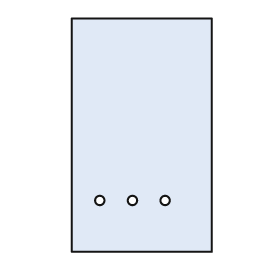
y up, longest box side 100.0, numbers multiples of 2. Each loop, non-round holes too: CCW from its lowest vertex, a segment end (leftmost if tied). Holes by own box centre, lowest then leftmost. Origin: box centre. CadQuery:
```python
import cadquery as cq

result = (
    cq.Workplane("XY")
    .moveTo(-30.0, -50.0)
    .lineTo(30.0, -50.0)
    .lineTo(30.0, 50.0)
    .lineTo(-30.0, 50.0)
    .close()
    .moveTo(-18.0, -28.0)
    .circle(2.0)
    .moveTo(-4.0, -28.0)
    .circle(2.0)
    .moveTo(10.0, -28.0)
    .circle(2.0)
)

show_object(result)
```